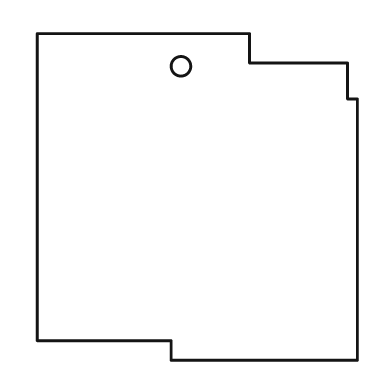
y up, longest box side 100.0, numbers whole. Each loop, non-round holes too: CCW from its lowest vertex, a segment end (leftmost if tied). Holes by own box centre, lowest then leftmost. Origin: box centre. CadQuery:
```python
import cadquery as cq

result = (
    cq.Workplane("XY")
    .moveTo(-8.0, -50.0)
    .lineTo(49.0, -50.0)
    .lineTo(49.0, 30.0)
    .lineTo(46.0, 30.0)
    .lineTo(46.0, 41.0)
    .lineTo(16.0, 41.0)
    .lineTo(16.0, 50.0)
    .lineTo(-49.0, 50.0)
    .lineTo(-49.0, -44.0)
    .lineTo(-8.0, -44.0)
    .close()
    .moveTo(-5.0, 40.0)
    .circle(3.0)
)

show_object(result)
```